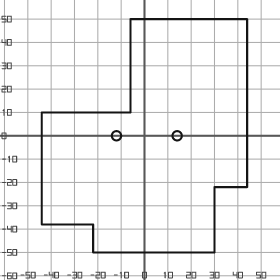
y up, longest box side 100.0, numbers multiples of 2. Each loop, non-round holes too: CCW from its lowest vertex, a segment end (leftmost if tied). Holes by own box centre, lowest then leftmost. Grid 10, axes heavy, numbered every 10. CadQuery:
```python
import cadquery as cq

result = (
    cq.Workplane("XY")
    .moveTo(-22.0, -50.0)
    .lineTo(30.0, -50.0)
    .lineTo(30.0, -22.0)
    .lineTo(44.0, -22.0)
    .lineTo(44.0, 50.0)
    .lineTo(-6.0, 50.0)
    .lineTo(-6.0, 10.0)
    .lineTo(-44.0, 10.0)
    .lineTo(-44.0, -38.0)
    .lineTo(-22.0, -38.0)
    .close()
    .moveTo(-12.0, 0.0)
    .circle(2.0)
    .moveTo(14.0, 0.0)
    .circle(2.0)
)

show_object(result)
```